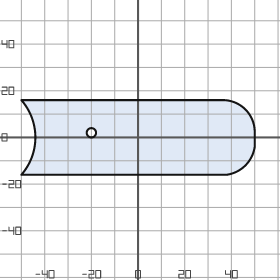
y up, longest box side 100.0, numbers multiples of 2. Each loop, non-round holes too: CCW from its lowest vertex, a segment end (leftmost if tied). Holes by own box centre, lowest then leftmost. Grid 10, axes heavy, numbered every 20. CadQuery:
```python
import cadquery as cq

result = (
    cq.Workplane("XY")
    .moveTo(-50.0, -16.0)
    .lineTo(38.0, -16.0)
    .threePointArc((46.0, -12.0), (50.0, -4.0))
    .lineTo(50.0, 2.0)
    .threePointArc((46.0, 12.0), (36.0, 16.0))
    .lineTo(-50.0, 16.0)
    .threePointArc((-44.0, 0.0), (-50.0, -16.0))
    .close()
    .moveTo(-20.0, 2.0)
    .circle(2.0)
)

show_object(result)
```